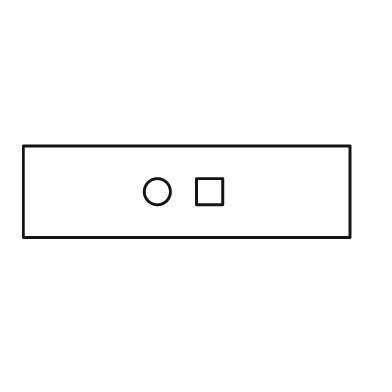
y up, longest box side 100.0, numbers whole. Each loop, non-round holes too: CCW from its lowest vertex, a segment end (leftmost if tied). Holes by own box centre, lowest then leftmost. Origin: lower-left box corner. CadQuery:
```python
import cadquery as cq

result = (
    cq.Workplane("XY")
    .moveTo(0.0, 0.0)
    .lineTo(100.0, 0.0)
    .lineTo(100.0, 28.0)
    .lineTo(0.0, 28.0)
    .close()
    .moveTo(41.0, 14.0)
    .circle(4.0)
    .moveTo(53.0, 10.0)
    .lineTo(61.0, 10.0)
    .lineTo(61.0, 18.0)
    .lineTo(53.0, 18.0)
    .close()
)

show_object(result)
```